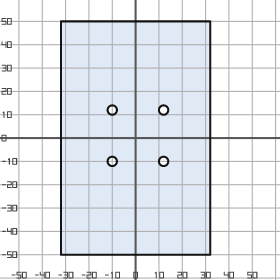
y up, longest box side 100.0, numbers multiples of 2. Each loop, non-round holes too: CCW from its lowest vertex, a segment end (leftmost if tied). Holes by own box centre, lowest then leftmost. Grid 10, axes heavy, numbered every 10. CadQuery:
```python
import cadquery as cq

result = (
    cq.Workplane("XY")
    .moveTo(-32.0, -50.0)
    .lineTo(32.0, -50.0)
    .lineTo(32.0, 50.0)
    .lineTo(-32.0, 50.0)
    .close()
    .moveTo(-10.0, -10.0)
    .circle(2.0)
    .moveTo(12.0, -10.0)
    .circle(2.0)
    .moveTo(-10.0, 12.0)
    .circle(2.0)
    .moveTo(12.0, 12.0)
    .circle(2.0)
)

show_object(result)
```